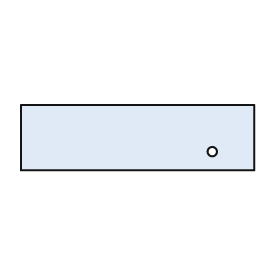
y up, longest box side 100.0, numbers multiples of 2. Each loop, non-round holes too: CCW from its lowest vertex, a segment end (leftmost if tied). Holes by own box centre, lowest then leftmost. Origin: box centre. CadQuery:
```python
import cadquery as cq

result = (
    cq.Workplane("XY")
    .moveTo(-50.0, -14.0)
    .lineTo(50.0, -14.0)
    .lineTo(50.0, 14.0)
    .lineTo(-50.0, 14.0)
    .close()
    .moveTo(32.0, -6.0)
    .circle(2.0)
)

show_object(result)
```